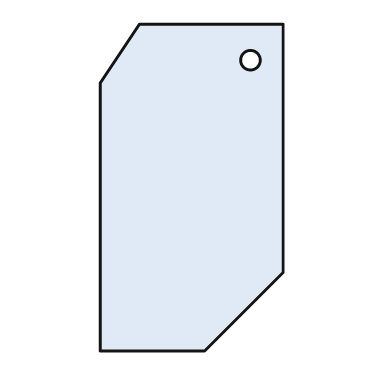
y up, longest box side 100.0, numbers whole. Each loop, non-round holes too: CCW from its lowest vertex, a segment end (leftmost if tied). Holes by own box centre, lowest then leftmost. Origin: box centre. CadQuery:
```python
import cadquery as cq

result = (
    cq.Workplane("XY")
    .moveTo(-28.0, -50.0)
    .lineTo(4.0, -50.0)
    .lineTo(28.0, -26.0)
    .lineTo(28.0, 50.0)
    .lineTo(-16.0, 50.0)
    .lineTo(-28.0, 32.0)
    .close()
    .moveTo(18.0, 39.0)
    .circle(3.0)
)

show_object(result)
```